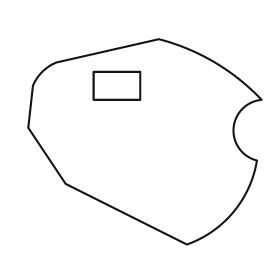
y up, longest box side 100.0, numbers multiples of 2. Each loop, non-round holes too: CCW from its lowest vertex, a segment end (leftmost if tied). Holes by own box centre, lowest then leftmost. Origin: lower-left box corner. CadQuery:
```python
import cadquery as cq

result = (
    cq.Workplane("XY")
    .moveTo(68.0, 0.0)
    .threePointArc((88.0, 14.0), (98.0, 36.0))
    .threePointArc((88.0, 50.0), (100.0, 62.0))
    .threePointArc((80.0, 78.0), (56.0, 88.0))
    .lineTo(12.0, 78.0)
    .threePointArc((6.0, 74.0), (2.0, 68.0))
    .lineTo(0.0, 50.0)
    .lineTo(16.0, 26.0)
    .close()
    .moveTo(28.0, 62.0)
    .lineTo(48.0, 62.0)
    .lineTo(48.0, 74.0)
    .lineTo(28.0, 74.0)
    .close()
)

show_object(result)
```